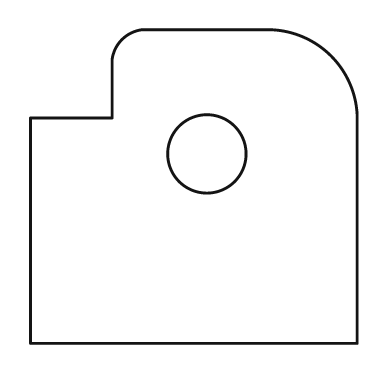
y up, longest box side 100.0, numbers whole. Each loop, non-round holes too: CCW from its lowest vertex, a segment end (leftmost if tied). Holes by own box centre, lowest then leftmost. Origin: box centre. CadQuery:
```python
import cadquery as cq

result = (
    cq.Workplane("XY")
    .moveTo(-50.0, -48.0)
    .lineTo(50.0, -48.0)
    .lineTo(50.0, 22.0)
    .threePointArc((42.0, 40.0), (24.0, 48.0))
    .lineTo(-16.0, 48.0)
    .threePointArc((-22.0, 45.0), (-25.0, 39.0))
    .lineTo(-25.0, 21.0)
    .lineTo(-50.0, 21.0)
    .close()
    .moveTo(4.0, 10.0)
    .circle(12.0)
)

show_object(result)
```